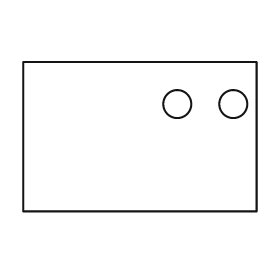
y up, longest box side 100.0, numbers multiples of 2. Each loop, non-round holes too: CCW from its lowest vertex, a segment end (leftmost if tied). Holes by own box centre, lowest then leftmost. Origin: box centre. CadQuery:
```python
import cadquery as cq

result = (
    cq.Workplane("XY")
    .moveTo(-50.0, -32.0)
    .lineTo(50.0, -32.0)
    .lineTo(50.0, 32.0)
    .lineTo(-50.0, 32.0)
    .close()
    .moveTo(16.0, 14.0)
    .circle(6.0)
    .moveTo(40.0, 14.0)
    .circle(6.0)
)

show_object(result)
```